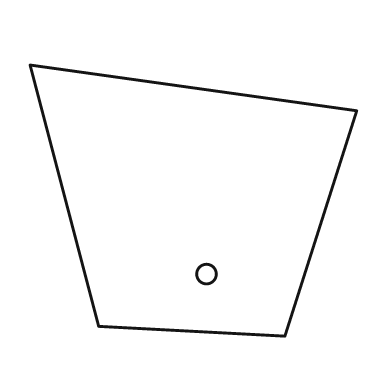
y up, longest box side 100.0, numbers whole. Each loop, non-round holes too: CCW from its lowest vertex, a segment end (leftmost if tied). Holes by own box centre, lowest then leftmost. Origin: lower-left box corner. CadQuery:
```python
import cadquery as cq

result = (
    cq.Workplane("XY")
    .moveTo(78.0, 0.0)
    .lineTo(100.0, 69.0)
    .lineTo(0.0, 83.0)
    .lineTo(21.0, 3.0)
    .close()
    .moveTo(54.0, 19.0)
    .circle(3.0)
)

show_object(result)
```